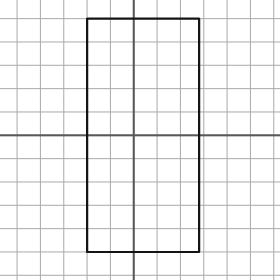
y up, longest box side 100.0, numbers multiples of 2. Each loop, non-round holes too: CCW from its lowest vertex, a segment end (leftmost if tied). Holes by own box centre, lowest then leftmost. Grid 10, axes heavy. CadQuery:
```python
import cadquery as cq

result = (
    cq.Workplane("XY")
    .moveTo(-20.0, -50.0)
    .lineTo(28.0, -50.0)
    .lineTo(28.0, 50.0)
    .lineTo(-20.0, 50.0)
    .close()
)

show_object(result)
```